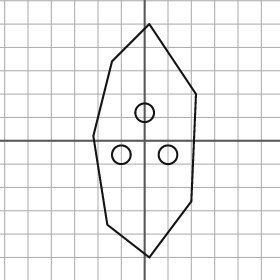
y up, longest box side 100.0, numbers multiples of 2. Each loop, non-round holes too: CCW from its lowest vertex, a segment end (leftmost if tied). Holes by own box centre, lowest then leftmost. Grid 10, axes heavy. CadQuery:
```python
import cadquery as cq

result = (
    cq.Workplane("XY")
    .moveTo(2.0, -50.0)
    .lineTo(20.0, -26.0)
    .lineTo(22.0, 20.0)
    .lineTo(2.0, 50.0)
    .lineTo(-14.0, 34.0)
    .lineTo(-22.0, 2.0)
    .lineTo(-16.0, -36.0)
    .close()
    .moveTo(-10.0, -6.0)
    .circle(4.0)
    .moveTo(10.0, -6.0)
    .circle(4.0)
    .moveTo(0.0, 12.0)
    .circle(4.0)
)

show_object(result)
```